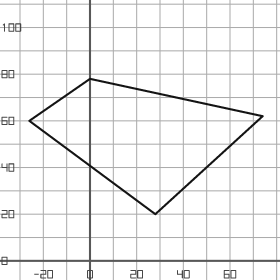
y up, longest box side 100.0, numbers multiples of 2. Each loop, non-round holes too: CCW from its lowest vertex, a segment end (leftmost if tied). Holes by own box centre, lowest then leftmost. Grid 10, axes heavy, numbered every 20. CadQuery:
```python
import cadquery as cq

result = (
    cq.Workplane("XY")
    .moveTo(28.0, 20.0)
    .lineTo(74.0, 62.0)
    .lineTo(0.0, 78.0)
    .lineTo(-26.0, 60.0)
    .close()
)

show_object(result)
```